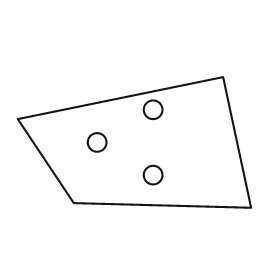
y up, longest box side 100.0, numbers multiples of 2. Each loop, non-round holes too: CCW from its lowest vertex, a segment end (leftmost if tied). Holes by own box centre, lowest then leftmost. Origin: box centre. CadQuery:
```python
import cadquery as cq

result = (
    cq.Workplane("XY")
    .moveTo(50.0, -28.0)
    .lineTo(38.0, 28.0)
    .lineTo(-50.0, 10.0)
    .lineTo(-26.0, -26.0)
    .close()
    .moveTo(8.0, -14.0)
    .circle(4.0)
    .moveTo(-16.0, 0.0)
    .circle(4.0)
    .moveTo(8.0, 14.0)
    .circle(4.0)
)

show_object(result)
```